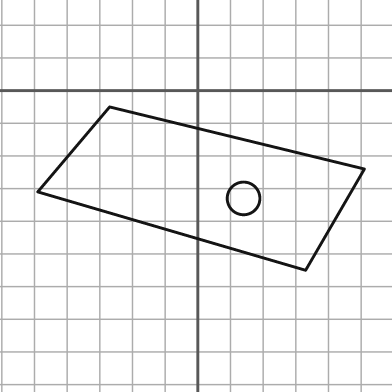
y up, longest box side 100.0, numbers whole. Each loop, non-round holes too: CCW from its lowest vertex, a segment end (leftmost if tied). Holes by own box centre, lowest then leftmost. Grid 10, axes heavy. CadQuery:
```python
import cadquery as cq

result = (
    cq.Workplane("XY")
    .moveTo(33.0, -55.0)
    .lineTo(51.0, -24.0)
    .lineTo(-27.0, -5.0)
    .lineTo(-49.0, -31.0)
    .close()
    .moveTo(14.0, -33.0)
    .circle(5.0)
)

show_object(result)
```